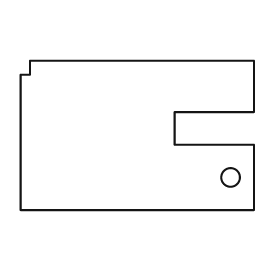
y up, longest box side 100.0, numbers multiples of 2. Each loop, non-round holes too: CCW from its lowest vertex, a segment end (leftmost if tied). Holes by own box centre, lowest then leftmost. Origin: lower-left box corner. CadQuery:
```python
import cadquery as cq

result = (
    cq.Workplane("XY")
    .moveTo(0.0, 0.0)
    .lineTo(100.0, 0.0)
    .lineTo(100.0, 28.0)
    .lineTo(66.0, 28.0)
    .lineTo(66.0, 42.0)
    .lineTo(100.0, 42.0)
    .lineTo(100.0, 64.0)
    .lineTo(4.0, 64.0)
    .lineTo(4.0, 58.0)
    .lineTo(0.0, 58.0)
    .close()
    .moveTo(90.0, 14.0)
    .circle(4.0)
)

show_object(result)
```